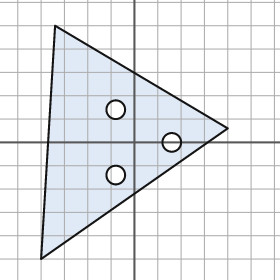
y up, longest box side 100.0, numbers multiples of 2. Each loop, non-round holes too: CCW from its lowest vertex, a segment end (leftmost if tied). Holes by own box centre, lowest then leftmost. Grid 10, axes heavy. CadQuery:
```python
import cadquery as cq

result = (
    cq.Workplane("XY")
    .moveTo(-40.0, -50.0)
    .lineTo(40.0, 6.0)
    .lineTo(-34.0, 50.0)
    .close()
    .moveTo(-8.0, -14.0)
    .circle(4.0)
    .moveTo(16.0, 0.0)
    .circle(4.0)
    .moveTo(-8.0, 14.0)
    .circle(4.0)
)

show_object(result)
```